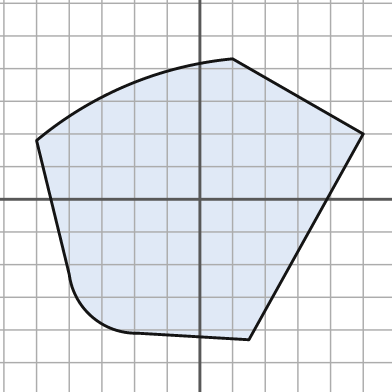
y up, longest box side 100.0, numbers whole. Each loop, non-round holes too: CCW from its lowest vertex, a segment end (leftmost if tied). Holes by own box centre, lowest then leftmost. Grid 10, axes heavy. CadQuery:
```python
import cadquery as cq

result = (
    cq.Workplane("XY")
    .moveTo(15.0, -43.0)
    .lineTo(50.0, 20.0)
    .lineTo(10.0, 43.0)
    .threePointArc((-22.0, 35.0), (-50.0, 18.0))
    .lineTo(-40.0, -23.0)
    .threePointArc((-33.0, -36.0), (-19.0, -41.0))
    .close()
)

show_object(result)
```